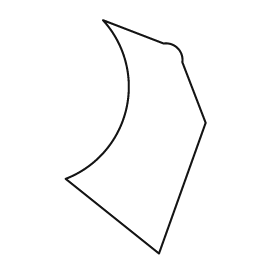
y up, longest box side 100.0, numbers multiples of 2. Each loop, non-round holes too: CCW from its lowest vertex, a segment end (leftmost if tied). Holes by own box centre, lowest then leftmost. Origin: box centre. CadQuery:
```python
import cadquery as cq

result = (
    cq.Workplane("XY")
    .moveTo(10.0, -50.0)
    .lineTo(30.0, 6.0)
    .lineTo(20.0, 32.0)
    .threePointArc((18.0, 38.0), (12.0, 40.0))
    .lineTo(-14.0, 50.0)
    .threePointArc((-4.0, 12.0), (-30.0, -18.0))
    .close()
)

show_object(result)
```